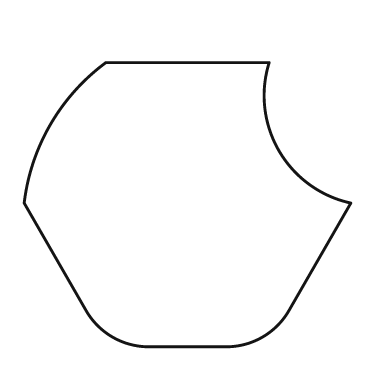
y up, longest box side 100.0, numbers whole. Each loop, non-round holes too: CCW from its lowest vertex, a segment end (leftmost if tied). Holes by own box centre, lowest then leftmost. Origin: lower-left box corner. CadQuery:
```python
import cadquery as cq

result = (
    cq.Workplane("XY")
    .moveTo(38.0, 0.0)
    .lineTo(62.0, 0.0)
    .threePointArc((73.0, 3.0), (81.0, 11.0))
    .lineTo(100.0, 44.0)
    .threePointArc((78.0, 60.0), (75.0, 87.0))
    .lineTo(25.0, 87.0)
    .threePointArc((8.0, 68.0), (0.0, 44.0))
    .lineTo(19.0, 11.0)
    .threePointArc((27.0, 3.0), (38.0, 0.0))
    .close()
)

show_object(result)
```